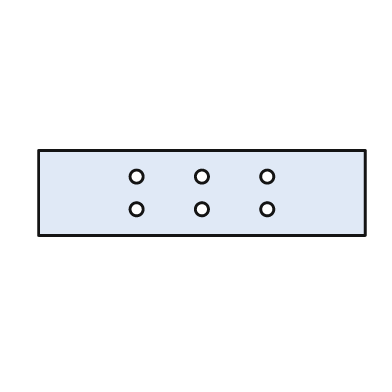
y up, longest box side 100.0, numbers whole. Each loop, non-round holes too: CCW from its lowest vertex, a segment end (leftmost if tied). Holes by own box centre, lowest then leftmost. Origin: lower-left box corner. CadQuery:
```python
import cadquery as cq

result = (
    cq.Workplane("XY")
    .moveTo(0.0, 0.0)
    .lineTo(100.0, 0.0)
    .lineTo(100.0, 26.0)
    .lineTo(0.0, 26.0)
    .close()
    .moveTo(30.0, 8.0)
    .circle(2.0)
    .moveTo(50.0, 8.0)
    .circle(2.0)
    .moveTo(70.0, 8.0)
    .circle(2.0)
    .moveTo(30.0, 18.0)
    .circle(2.0)
    .moveTo(50.0, 18.0)
    .circle(2.0)
    .moveTo(70.0, 18.0)
    .circle(2.0)
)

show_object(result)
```